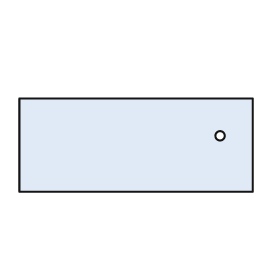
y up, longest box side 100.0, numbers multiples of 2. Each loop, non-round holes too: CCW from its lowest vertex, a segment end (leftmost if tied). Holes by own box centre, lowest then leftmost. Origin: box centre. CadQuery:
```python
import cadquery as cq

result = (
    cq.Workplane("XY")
    .moveTo(-50.0, -20.0)
    .lineTo(50.0, -20.0)
    .lineTo(50.0, 20.0)
    .lineTo(-50.0, 20.0)
    .close()
    .moveTo(36.0, 4.0)
    .circle(2.0)
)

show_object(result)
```